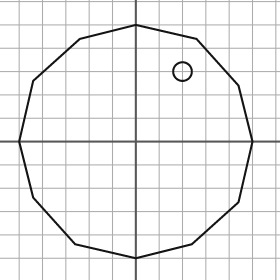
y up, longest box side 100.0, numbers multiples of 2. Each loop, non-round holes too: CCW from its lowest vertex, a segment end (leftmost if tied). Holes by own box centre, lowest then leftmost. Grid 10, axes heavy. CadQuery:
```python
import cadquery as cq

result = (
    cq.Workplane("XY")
    .moveTo(0.0, -50.0)
    .lineTo(24.0, -44.0)
    .lineTo(44.0, -26.0)
    .lineTo(50.0, 0.0)
    .lineTo(44.0, 24.0)
    .lineTo(26.0, 44.0)
    .lineTo(0.0, 50.0)
    .lineTo(-24.0, 44.0)
    .lineTo(-44.0, 26.0)
    .lineTo(-50.0, 0.0)
    .lineTo(-44.0, -24.0)
    .lineTo(-26.0, -44.0)
    .close()
    .moveTo(20.0, 30.0)
    .circle(4.0)
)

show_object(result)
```